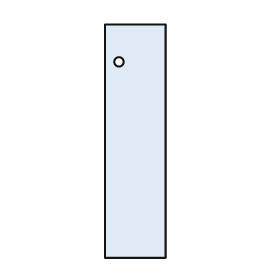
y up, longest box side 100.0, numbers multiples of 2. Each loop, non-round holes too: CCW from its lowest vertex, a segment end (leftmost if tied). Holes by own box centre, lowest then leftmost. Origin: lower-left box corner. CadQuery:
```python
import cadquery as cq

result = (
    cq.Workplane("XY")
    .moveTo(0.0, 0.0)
    .lineTo(26.0, 0.0)
    .lineTo(26.0, 100.0)
    .lineTo(0.0, 100.0)
    .close()
    .moveTo(6.0, 84.0)
    .circle(2.0)
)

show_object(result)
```